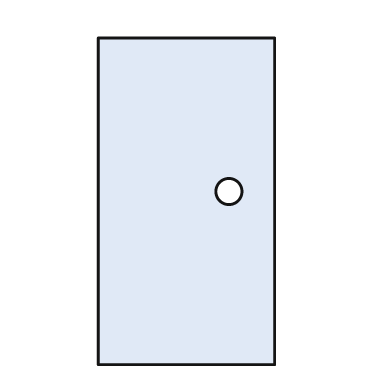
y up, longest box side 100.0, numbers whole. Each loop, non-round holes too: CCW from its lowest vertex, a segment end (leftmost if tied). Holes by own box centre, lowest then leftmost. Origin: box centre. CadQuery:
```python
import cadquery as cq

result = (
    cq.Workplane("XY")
    .moveTo(-27.0, -50.0)
    .lineTo(27.0, -50.0)
    .lineTo(27.0, 50.0)
    .lineTo(-27.0, 50.0)
    .close()
    .moveTo(13.0, 3.0)
    .circle(4.0)
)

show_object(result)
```